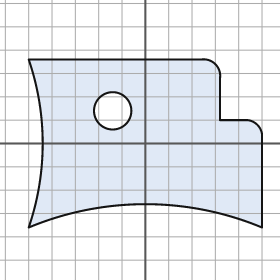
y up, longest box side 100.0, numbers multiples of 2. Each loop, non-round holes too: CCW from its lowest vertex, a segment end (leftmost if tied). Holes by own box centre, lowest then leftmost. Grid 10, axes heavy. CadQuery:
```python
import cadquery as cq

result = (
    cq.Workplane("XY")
    .moveTo(-50.0, -36.0)
    .threePointArc((0.0, -26.0), (50.0, -36.0))
    .lineTo(50.0, 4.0)
    .threePointArc((48.0, 8.0), (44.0, 10.0))
    .lineTo(32.0, 10.0)
    .lineTo(32.0, 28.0)
    .threePointArc((30.0, 34.0), (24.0, 36.0))
    .lineTo(-50.0, 36.0)
    .threePointArc((-44.0, 0.0), (-50.0, -36.0))
    .close()
    .moveTo(-14.0, 14.0)
    .circle(8.0)
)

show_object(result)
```